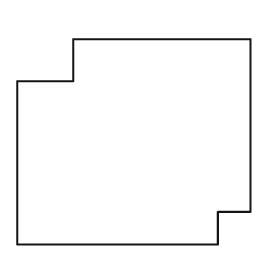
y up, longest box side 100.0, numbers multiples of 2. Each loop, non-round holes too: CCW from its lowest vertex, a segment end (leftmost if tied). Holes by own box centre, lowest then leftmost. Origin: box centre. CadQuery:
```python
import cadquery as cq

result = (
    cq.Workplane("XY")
    .moveTo(-50.0, -44.0)
    .lineTo(36.0, -44.0)
    .lineTo(36.0, -30.0)
    .lineTo(50.0, -30.0)
    .lineTo(50.0, 44.0)
    .lineTo(-26.0, 44.0)
    .lineTo(-26.0, 26.0)
    .lineTo(-50.0, 26.0)
    .close()
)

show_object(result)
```